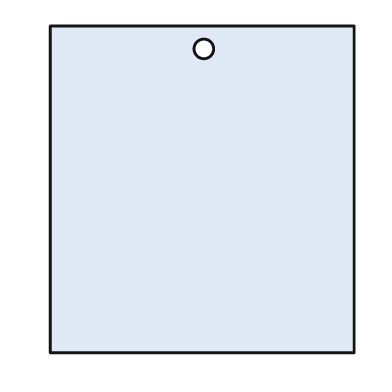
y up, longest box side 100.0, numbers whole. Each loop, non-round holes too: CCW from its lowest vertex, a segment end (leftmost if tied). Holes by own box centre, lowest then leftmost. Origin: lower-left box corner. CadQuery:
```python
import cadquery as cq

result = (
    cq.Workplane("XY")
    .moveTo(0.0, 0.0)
    .lineTo(93.0, 0.0)
    .lineTo(93.0, 100.0)
    .lineTo(0.0, 100.0)
    .close()
    .moveTo(47.0, 93.0)
    .circle(3.0)
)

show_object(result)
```